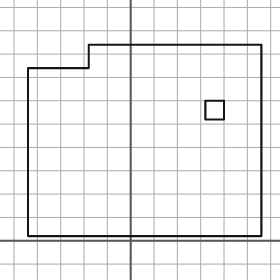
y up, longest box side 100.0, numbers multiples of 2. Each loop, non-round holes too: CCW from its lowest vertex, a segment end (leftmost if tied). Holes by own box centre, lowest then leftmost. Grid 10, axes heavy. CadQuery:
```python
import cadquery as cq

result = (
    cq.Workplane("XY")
    .moveTo(-44.0, 2.0)
    .lineTo(56.0, 2.0)
    .lineTo(56.0, 84.0)
    .lineTo(-18.0, 84.0)
    .lineTo(-18.0, 74.0)
    .lineTo(-44.0, 74.0)
    .close()
    .moveTo(32.0, 52.0)
    .lineTo(40.0, 52.0)
    .lineTo(40.0, 60.0)
    .lineTo(32.0, 60.0)
    .close()
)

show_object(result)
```